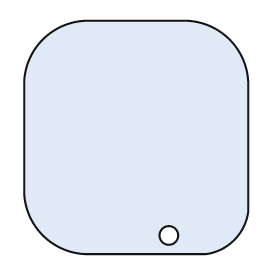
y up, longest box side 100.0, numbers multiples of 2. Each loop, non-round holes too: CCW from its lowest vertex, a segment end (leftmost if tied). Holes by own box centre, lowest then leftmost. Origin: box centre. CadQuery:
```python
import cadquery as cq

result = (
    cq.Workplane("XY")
    .moveTo(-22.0, -50.0)
    .lineTo(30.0, -50.0)
    .threePointArc((42.0, -44.0), (48.0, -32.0))
    .lineTo(48.0, 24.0)
    .threePointArc((40.0, 42.0), (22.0, 50.0))
    .lineTo(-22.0, 50.0)
    .threePointArc((-40.0, 42.0), (-48.0, 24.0))
    .lineTo(-48.0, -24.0)
    .threePointArc((-40.0, -42.0), (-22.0, -50.0))
    .close()
    .moveTo(14.0, -42.0)
    .circle(4.0)
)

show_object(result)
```